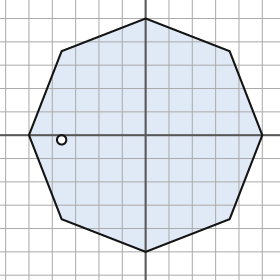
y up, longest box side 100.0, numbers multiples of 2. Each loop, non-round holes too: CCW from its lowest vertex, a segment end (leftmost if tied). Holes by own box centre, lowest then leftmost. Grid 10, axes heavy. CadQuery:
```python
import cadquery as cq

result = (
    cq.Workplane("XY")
    .moveTo(0.0, -50.0)
    .lineTo(36.0, -36.0)
    .lineTo(50.0, 0.0)
    .lineTo(36.0, 36.0)
    .lineTo(0.0, 50.0)
    .lineTo(-36.0, 36.0)
    .lineTo(-50.0, 0.0)
    .lineTo(-36.0, -36.0)
    .close()
    .moveTo(-36.0, -2.0)
    .circle(2.0)
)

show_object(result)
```